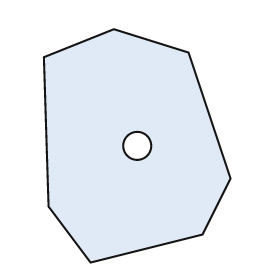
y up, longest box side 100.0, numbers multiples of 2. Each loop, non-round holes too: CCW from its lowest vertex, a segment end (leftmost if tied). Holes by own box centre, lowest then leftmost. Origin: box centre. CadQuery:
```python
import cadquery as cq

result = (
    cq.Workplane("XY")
    .moveTo(-20.0, -50.0)
    .lineTo(28.0, -38.0)
    .lineTo(40.0, -14.0)
    .lineTo(22.0, 40.0)
    .lineTo(-10.0, 50.0)
    .lineTo(-40.0, 38.0)
    .lineTo(-38.0, -26.0)
    .close()
    .moveTo(0.0, 0.0)
    .circle(6.0)
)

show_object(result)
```